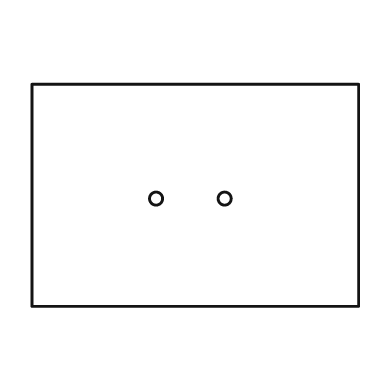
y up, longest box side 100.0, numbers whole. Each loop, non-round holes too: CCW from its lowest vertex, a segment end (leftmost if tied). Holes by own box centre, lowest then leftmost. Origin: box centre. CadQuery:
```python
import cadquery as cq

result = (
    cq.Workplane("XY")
    .moveTo(-50.0, -34.0)
    .lineTo(50.0, -34.0)
    .lineTo(50.0, 34.0)
    .lineTo(-50.0, 34.0)
    .close()
    .moveTo(-12.0, -1.0)
    .circle(2.0)
    .moveTo(9.0, -1.0)
    .circle(2.0)
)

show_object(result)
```